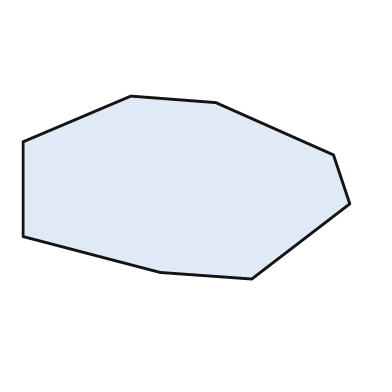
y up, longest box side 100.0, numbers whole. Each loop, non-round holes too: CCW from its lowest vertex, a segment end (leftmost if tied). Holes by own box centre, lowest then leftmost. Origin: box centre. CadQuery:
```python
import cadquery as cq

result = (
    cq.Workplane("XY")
    .moveTo(20.0, -28.0)
    .lineTo(50.0, -5.0)
    .lineTo(45.0, 10.0)
    .lineTo(9.0, 26.0)
    .lineTo(-17.0, 28.0)
    .lineTo(-50.0, 14.0)
    .lineTo(-50.0, -15.0)
    .lineTo(-8.0, -26.0)
    .close()
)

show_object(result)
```